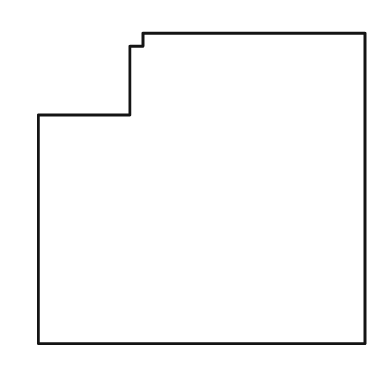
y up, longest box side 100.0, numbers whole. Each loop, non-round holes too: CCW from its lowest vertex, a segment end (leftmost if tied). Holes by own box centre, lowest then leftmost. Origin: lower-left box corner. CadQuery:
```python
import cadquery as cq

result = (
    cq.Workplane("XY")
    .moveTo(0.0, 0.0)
    .lineTo(100.0, 0.0)
    .lineTo(100.0, 95.0)
    .lineTo(32.0, 95.0)
    .lineTo(32.0, 91.0)
    .lineTo(28.0, 91.0)
    .lineTo(28.0, 70.0)
    .lineTo(0.0, 70.0)
    .close()
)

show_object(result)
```